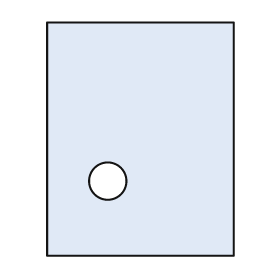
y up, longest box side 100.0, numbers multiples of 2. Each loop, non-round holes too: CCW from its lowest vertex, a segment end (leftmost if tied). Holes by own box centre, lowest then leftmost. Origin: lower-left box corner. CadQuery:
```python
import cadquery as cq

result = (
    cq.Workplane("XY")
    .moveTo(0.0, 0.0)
    .lineTo(80.0, 0.0)
    .lineTo(80.0, 100.0)
    .lineTo(0.0, 100.0)
    .close()
    .moveTo(26.0, 32.0)
    .circle(8.0)
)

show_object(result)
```